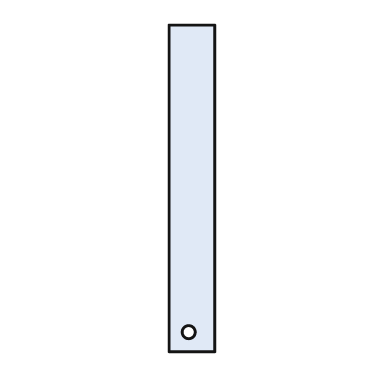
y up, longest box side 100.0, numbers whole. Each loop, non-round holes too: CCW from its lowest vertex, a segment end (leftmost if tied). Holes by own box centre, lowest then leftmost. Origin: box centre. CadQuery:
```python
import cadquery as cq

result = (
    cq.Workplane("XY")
    .moveTo(-7.0, -50.0)
    .lineTo(7.0, -50.0)
    .lineTo(7.0, 50.0)
    .lineTo(-7.0, 50.0)
    .close()
    .moveTo(-1.0, -44.0)
    .circle(2.0)
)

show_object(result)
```